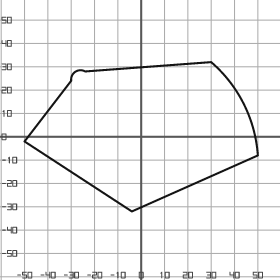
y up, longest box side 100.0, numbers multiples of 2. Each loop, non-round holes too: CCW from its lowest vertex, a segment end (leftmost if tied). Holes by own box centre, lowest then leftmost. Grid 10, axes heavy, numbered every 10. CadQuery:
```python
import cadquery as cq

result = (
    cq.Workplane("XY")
    .moveTo(-4.0, -32.0)
    .lineTo(50.0, -8.0)
    .threePointArc((44.0, 14.0), (30.0, 32.0))
    .lineTo(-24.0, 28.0)
    .threePointArc((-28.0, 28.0), (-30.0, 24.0))
    .lineTo(-50.0, -2.0)
    .close()
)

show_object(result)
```